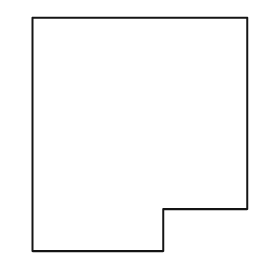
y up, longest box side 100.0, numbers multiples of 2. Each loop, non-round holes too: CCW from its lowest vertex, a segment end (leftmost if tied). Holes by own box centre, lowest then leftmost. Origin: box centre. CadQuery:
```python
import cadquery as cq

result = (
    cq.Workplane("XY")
    .moveTo(-46.0, -50.0)
    .lineTo(10.0, -50.0)
    .lineTo(10.0, -32.0)
    .lineTo(46.0, -32.0)
    .lineTo(46.0, 50.0)
    .lineTo(-46.0, 50.0)
    .close()
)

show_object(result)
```